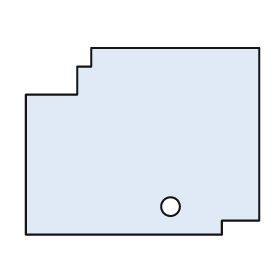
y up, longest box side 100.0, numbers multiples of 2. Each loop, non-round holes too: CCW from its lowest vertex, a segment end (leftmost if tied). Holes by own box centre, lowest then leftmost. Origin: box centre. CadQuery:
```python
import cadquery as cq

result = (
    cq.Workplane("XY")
    .moveTo(-50.0, -40.0)
    .lineTo(34.0, -40.0)
    .lineTo(34.0, -34.0)
    .lineTo(50.0, -34.0)
    .lineTo(50.0, 40.0)
    .lineTo(-22.0, 40.0)
    .lineTo(-22.0, 32.0)
    .lineTo(-28.0, 32.0)
    .lineTo(-28.0, 20.0)
    .lineTo(-50.0, 20.0)
    .close()
    .moveTo(12.0, -28.0)
    .circle(4.0)
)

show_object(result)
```